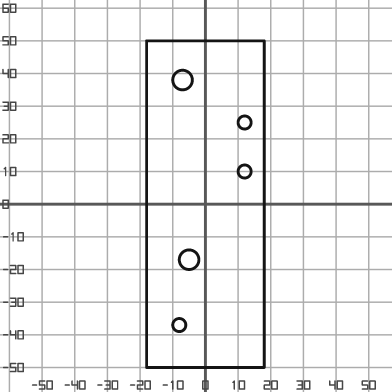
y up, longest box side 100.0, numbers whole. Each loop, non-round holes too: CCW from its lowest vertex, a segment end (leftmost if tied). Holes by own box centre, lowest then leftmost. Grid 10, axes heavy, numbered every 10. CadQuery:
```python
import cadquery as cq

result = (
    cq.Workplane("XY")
    .moveTo(-18.0, -50.0)
    .lineTo(18.0, -50.0)
    .lineTo(18.0, 50.0)
    .lineTo(-18.0, 50.0)
    .close()
    .moveTo(-8.0, -37.0)
    .circle(2.0)
    .moveTo(-5.0, -17.0)
    .circle(3.0)
    .moveTo(12.0, 10.0)
    .circle(2.0)
    .moveTo(12.0, 25.0)
    .circle(2.0)
    .moveTo(-7.0, 38.0)
    .circle(3.0)
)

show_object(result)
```